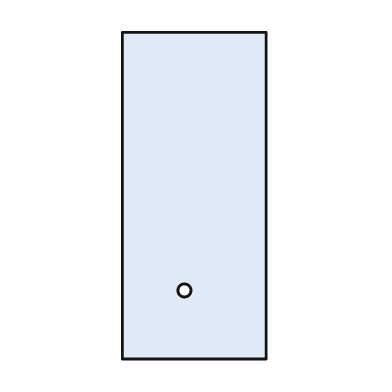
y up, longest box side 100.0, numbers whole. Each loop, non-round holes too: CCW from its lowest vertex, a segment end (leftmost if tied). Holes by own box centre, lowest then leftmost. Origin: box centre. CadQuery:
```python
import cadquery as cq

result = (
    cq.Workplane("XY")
    .moveTo(-22.0, -50.0)
    .lineTo(22.0, -50.0)
    .lineTo(22.0, 50.0)
    .lineTo(-22.0, 50.0)
    .close()
    .moveTo(-3.0, -29.0)
    .circle(2.0)
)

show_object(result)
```